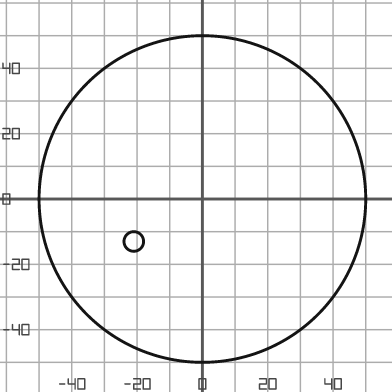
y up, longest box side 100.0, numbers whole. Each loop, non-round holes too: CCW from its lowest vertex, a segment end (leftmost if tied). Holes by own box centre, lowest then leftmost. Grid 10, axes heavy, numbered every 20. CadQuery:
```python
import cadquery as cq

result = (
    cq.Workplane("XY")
    .moveTo(0.0, 0.0)
    .circle(50.0)
    .moveTo(-21.0, -13.0)
    .circle(3.0)
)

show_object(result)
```